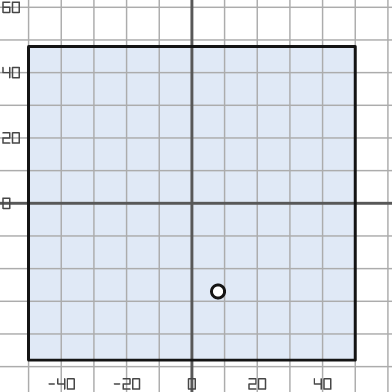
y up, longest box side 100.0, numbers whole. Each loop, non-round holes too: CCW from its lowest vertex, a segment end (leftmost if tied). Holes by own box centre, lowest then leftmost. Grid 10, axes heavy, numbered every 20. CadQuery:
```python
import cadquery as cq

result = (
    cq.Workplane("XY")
    .moveTo(-50.0, -48.0)
    .lineTo(50.0, -48.0)
    .lineTo(50.0, 48.0)
    .lineTo(-50.0, 48.0)
    .close()
    .moveTo(8.0, -27.0)
    .circle(2.0)
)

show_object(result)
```